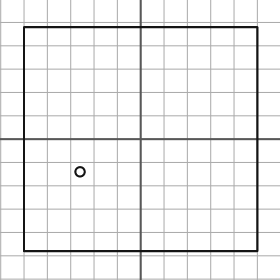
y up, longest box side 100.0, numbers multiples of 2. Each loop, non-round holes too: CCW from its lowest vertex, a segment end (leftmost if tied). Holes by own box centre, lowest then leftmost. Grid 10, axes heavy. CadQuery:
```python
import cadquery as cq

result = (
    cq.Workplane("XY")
    .moveTo(-50.0, -48.0)
    .lineTo(50.0, -48.0)
    .lineTo(50.0, 48.0)
    .lineTo(-50.0, 48.0)
    .close()
    .moveTo(-26.0, -14.0)
    .circle(2.0)
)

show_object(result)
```